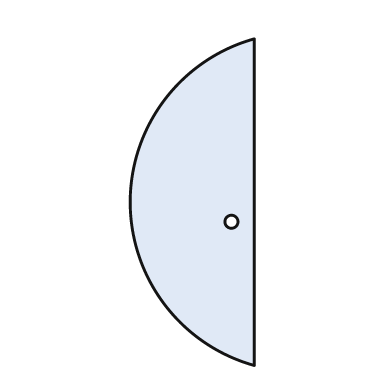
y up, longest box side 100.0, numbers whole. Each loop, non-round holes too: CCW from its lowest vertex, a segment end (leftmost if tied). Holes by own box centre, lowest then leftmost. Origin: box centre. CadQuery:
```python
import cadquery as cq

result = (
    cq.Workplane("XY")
    .moveTo(19.0, -50.0)
    .lineTo(19.0, 50.0)
    .threePointArc((-19.0, 0.0), (19.0, -50.0))
    .close()
    .moveTo(12.0, -6.0)
    .circle(2.0)
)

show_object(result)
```